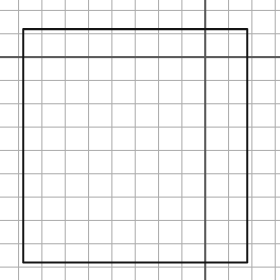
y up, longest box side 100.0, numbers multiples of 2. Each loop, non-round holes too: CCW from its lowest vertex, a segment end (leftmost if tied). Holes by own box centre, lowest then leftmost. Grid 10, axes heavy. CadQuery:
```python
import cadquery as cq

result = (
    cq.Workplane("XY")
    .moveTo(-78.0, -88.0)
    .lineTo(18.0, -88.0)
    .lineTo(18.0, 12.0)
    .lineTo(-78.0, 12.0)
    .close()
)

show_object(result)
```